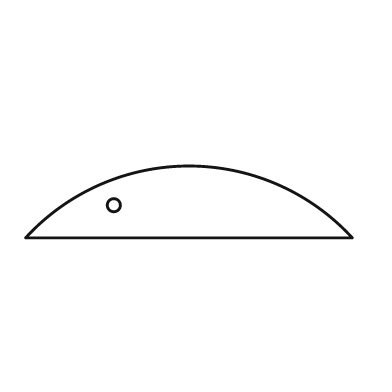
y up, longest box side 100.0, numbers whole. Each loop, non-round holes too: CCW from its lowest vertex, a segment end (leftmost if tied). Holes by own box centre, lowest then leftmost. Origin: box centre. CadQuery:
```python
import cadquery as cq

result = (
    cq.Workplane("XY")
    .moveTo(-50.0, -11.0)
    .lineTo(50.0, -11.0)
    .threePointArc((0.0, 11.0), (-50.0, -11.0))
    .close()
    .moveTo(-23.0, -1.0)
    .circle(2.0)
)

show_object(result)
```